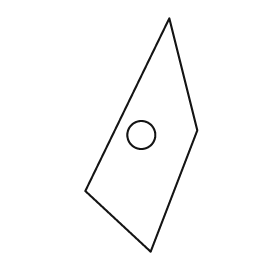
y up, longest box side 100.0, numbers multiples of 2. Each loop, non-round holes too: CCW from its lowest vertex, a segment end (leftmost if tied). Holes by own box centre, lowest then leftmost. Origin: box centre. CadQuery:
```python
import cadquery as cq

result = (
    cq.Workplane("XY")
    .moveTo(4.0, -50.0)
    .lineTo(24.0, 2.0)
    .lineTo(12.0, 50.0)
    .lineTo(-24.0, -24.0)
    .close()
    .moveTo(0.0, 0.0)
    .circle(6.0)
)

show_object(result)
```